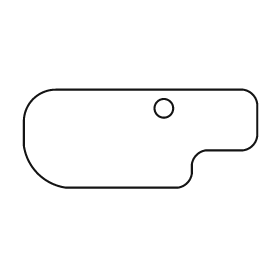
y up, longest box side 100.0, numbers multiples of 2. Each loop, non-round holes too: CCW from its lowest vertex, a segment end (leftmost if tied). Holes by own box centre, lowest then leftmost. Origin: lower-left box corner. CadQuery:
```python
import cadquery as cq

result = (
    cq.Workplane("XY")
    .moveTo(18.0, 0.0)
    .lineTo(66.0, 0.0)
    .threePointArc((70.0, 2.0), (72.0, 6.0))
    .lineTo(72.0, 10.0)
    .threePointArc((74.0, 14.0), (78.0, 16.0))
    .lineTo(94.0, 16.0)
    .threePointArc((98.0, 18.0), (100.0, 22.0))
    .lineTo(100.0, 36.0)
    .threePointArc((98.0, 40.0), (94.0, 42.0))
    .lineTo(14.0, 42.0)
    .threePointArc((4.0, 38.0), (0.0, 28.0))
    .lineTo(0.0, 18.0)
    .threePointArc((6.0, 6.0), (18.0, 0.0))
    .close()
    .moveTo(60.0, 34.0)
    .circle(4.0)
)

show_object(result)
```